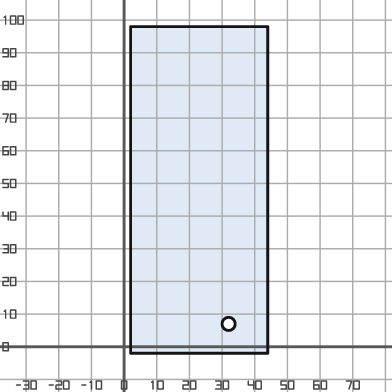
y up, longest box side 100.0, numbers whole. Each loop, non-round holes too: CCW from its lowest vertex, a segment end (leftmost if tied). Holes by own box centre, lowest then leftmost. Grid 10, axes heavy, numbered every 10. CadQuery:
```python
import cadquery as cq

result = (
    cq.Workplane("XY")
    .moveTo(2.0, -2.0)
    .lineTo(44.0, -2.0)
    .lineTo(44.0, 98.0)
    .lineTo(2.0, 98.0)
    .close()
    .moveTo(32.0, 7.0)
    .circle(2.0)
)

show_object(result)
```